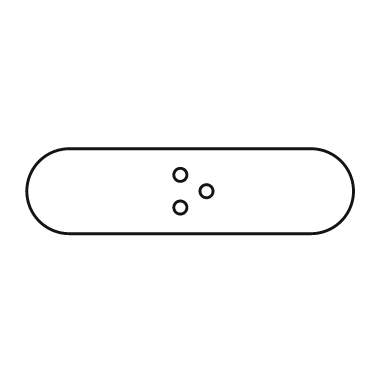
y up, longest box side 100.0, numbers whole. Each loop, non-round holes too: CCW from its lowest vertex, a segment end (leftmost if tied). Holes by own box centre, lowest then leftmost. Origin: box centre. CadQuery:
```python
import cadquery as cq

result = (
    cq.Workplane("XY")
    .moveTo(-37.0, -13.0)
    .lineTo(37.0, -13.0)
    .threePointArc((50.0, 0.0), (37.0, 13.0))
    .lineTo(-37.0, 13.0)
    .threePointArc((-50.0, 0.0), (-37.0, -13.0))
    .close()
    .moveTo(-3.0, -5.0)
    .circle(2.0)
    .moveTo(5.0, 0.0)
    .circle(2.0)
    .moveTo(-3.0, 5.0)
    .circle(2.0)
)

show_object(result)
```